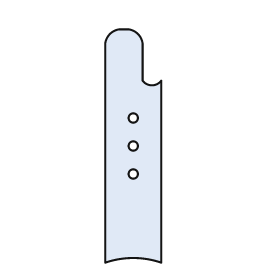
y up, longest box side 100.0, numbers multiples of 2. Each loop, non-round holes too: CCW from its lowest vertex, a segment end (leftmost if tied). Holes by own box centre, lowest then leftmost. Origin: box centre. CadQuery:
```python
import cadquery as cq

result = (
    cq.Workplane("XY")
    .moveTo(-12.0, -50.0)
    .threePointArc((0.0, -48.0), (12.0, -50.0))
    .lineTo(12.0, 28.0)
    .threePointArc((8.0, 26.0), (4.0, 28.0))
    .lineTo(4.0, 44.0)
    .threePointArc((2.0, 48.0), (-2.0, 50.0))
    .lineTo(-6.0, 50.0)
    .threePointArc((-10.0, 48.0), (-12.0, 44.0))
    .close()
    .moveTo(0.0, -12.0)
    .circle(2.0)
    .moveTo(0.0, 0.0)
    .circle(2.0)
    .moveTo(0.0, 12.0)
    .circle(2.0)
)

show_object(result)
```